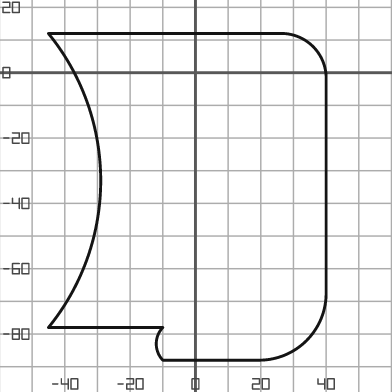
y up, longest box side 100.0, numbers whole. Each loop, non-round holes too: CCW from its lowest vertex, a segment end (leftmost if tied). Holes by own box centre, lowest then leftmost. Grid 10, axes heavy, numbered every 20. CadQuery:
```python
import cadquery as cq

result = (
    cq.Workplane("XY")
    .moveTo(-10.0, -88.0)
    .lineTo(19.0, -88.0)
    .threePointArc((34.0, -82.0), (40.0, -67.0))
    .lineTo(40.0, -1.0)
    .threePointArc((36.0, 8.0), (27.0, 12.0))
    .lineTo(-45.0, 12.0)
    .threePointArc((-29.0, -33.0), (-45.0, -78.0))
    .lineTo(-10.0, -78.0)
    .threePointArc((-12.0, -83.0), (-10.0, -88.0))
    .close()
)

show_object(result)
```